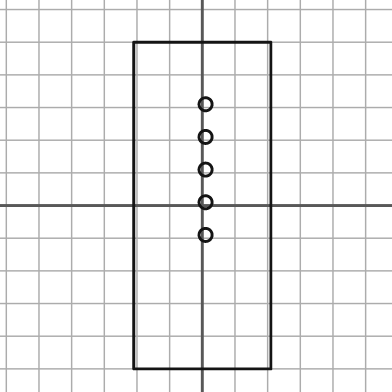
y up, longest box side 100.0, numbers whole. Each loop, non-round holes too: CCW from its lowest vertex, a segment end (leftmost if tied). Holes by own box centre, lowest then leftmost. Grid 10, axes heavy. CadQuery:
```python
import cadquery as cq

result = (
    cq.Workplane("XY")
    .moveTo(-21.0, -50.0)
    .lineTo(21.0, -50.0)
    .lineTo(21.0, 50.0)
    .lineTo(-21.0, 50.0)
    .close()
    .moveTo(1.0, -9.0)
    .circle(2.0)
    .moveTo(1.0, 1.0)
    .circle(2.0)
    .moveTo(1.0, 11.0)
    .circle(2.0)
    .moveTo(1.0, 21.0)
    .circle(2.0)
    .moveTo(1.0, 31.0)
    .circle(2.0)
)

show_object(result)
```